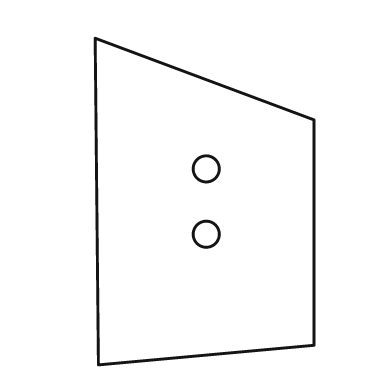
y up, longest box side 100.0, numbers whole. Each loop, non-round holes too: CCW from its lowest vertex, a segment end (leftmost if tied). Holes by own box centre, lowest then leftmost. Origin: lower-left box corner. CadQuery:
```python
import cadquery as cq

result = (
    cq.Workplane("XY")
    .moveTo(1.0, 0.0)
    .lineTo(67.0, 6.0)
    .lineTo(67.0, 75.0)
    .lineTo(0.0, 100.0)
    .close()
    .moveTo(34.0, 40.0)
    .circle(4.0)
    .moveTo(34.0, 60.0)
    .circle(4.0)
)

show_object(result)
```